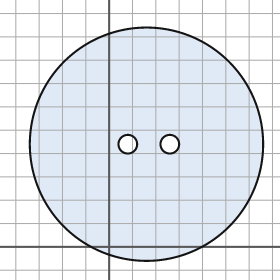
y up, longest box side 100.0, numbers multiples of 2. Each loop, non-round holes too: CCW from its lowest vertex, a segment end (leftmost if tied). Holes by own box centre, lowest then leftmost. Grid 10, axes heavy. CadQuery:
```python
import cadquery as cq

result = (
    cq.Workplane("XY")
    .moveTo(16.0, 44.0)
    .circle(50.0)
    .moveTo(8.0, 44.0)
    .circle(4.0)
    .moveTo(26.0, 44.0)
    .circle(4.0)
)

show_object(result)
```